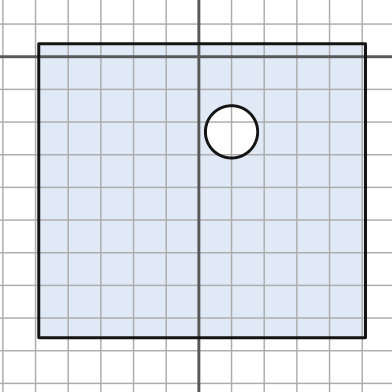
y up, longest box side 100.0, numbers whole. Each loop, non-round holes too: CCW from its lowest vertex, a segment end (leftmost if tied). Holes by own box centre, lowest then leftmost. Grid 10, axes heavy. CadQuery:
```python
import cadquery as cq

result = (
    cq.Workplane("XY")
    .moveTo(-49.0, -86.0)
    .lineTo(51.0, -86.0)
    .lineTo(51.0, 4.0)
    .lineTo(-49.0, 4.0)
    .close()
    .moveTo(10.0, -23.0)
    .circle(8.0)
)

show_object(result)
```